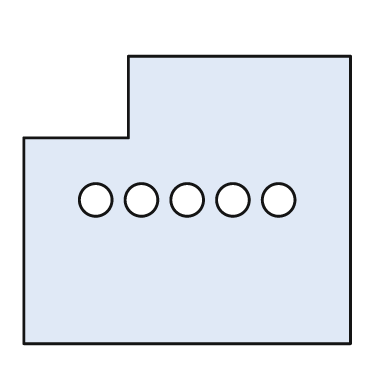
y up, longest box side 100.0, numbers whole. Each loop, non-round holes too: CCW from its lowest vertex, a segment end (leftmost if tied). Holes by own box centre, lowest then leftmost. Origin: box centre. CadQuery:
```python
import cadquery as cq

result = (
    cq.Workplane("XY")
    .moveTo(-50.0, -44.0)
    .lineTo(50.0, -44.0)
    .lineTo(50.0, 44.0)
    .lineTo(-18.0, 44.0)
    .lineTo(-18.0, 19.0)
    .lineTo(-50.0, 19.0)
    .close()
    .moveTo(-28.0, 0.0)
    .circle(5.0)
    .moveTo(-14.0, 0.0)
    .circle(5.0)
    .moveTo(0.0, 0.0)
    .circle(5.0)
    .moveTo(14.0, 0.0)
    .circle(5.0)
    .moveTo(28.0, 0.0)
    .circle(5.0)
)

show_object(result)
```